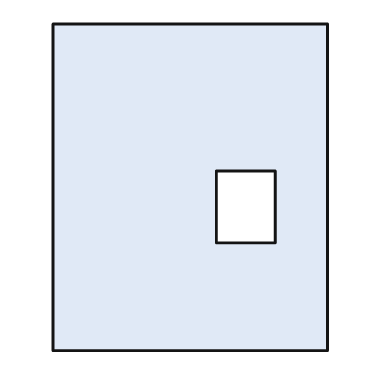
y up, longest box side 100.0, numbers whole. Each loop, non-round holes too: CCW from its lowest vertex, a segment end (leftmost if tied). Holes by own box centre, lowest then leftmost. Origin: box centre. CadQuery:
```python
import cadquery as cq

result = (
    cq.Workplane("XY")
    .moveTo(-42.0, -50.0)
    .lineTo(42.0, -50.0)
    .lineTo(42.0, 50.0)
    .lineTo(-42.0, 50.0)
    .close()
    .moveTo(8.0, -17.0)
    .lineTo(26.0, -17.0)
    .lineTo(26.0, 5.0)
    .lineTo(8.0, 5.0)
    .close()
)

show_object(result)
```